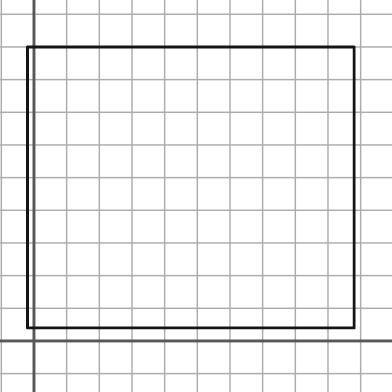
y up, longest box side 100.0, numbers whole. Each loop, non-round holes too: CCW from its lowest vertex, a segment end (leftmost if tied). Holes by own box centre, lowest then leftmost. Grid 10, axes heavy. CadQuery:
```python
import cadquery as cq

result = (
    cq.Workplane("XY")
    .moveTo(-2.0, 4.0)
    .lineTo(98.0, 4.0)
    .lineTo(98.0, 90.0)
    .lineTo(-2.0, 90.0)
    .close()
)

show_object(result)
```